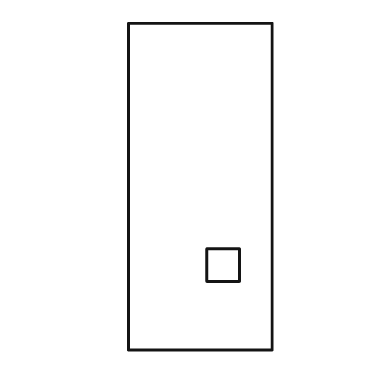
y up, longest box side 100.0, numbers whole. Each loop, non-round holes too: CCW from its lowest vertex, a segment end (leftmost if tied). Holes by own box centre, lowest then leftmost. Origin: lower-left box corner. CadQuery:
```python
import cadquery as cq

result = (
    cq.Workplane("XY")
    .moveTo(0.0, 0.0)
    .lineTo(44.0, 0.0)
    .lineTo(44.0, 100.0)
    .lineTo(0.0, 100.0)
    .close()
    .moveTo(24.0, 21.0)
    .lineTo(34.0, 21.0)
    .lineTo(34.0, 31.0)
    .lineTo(24.0, 31.0)
    .close()
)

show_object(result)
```